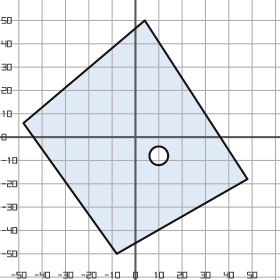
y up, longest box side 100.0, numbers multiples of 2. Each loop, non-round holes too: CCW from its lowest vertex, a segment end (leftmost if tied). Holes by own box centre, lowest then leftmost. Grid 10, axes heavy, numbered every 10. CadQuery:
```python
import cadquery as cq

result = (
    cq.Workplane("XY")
    .moveTo(-8.0, -50.0)
    .lineTo(48.0, -18.0)
    .lineTo(4.0, 50.0)
    .lineTo(-48.0, 6.0)
    .close()
    .moveTo(10.0, -8.0)
    .circle(4.0)
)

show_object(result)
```